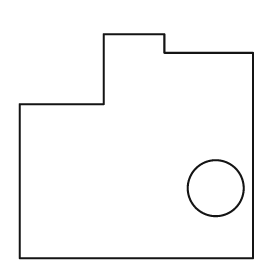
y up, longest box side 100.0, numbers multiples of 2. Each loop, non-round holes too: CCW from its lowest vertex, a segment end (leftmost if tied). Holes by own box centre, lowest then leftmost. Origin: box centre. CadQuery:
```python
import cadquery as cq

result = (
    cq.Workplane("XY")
    .moveTo(-50.0, -48.0)
    .lineTo(50.0, -48.0)
    .lineTo(50.0, 40.0)
    .lineTo(12.0, 40.0)
    .lineTo(12.0, 48.0)
    .lineTo(-14.0, 48.0)
    .lineTo(-14.0, 18.0)
    .lineTo(-50.0, 18.0)
    .close()
    .moveTo(34.0, -18.0)
    .circle(12.0)
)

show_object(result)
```